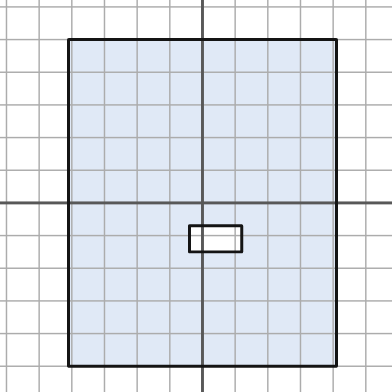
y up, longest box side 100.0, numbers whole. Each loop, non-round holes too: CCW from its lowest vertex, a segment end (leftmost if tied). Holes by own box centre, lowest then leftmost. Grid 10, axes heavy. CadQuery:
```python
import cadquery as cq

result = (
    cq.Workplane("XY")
    .moveTo(-41.0, -50.0)
    .lineTo(41.0, -50.0)
    .lineTo(41.0, 50.0)
    .lineTo(-41.0, 50.0)
    .close()
    .moveTo(-4.0, -15.0)
    .lineTo(12.0, -15.0)
    .lineTo(12.0, -7.0)
    .lineTo(-4.0, -7.0)
    .close()
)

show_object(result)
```